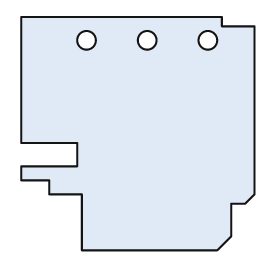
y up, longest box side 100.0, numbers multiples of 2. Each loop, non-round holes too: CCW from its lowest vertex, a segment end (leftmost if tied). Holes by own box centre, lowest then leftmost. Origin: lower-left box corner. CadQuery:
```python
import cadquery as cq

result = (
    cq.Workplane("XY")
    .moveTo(26.0, 0.0)
    .lineTo(84.0, 0.0)
    .lineTo(90.0, 6.0)
    .lineTo(90.0, 20.0)
    .lineTo(96.0, 20.0)
    .lineTo(100.0, 24.0)
    .lineTo(100.0, 96.0)
    .lineTo(86.0, 96.0)
    .lineTo(86.0, 100.0)
    .lineTo(0.0, 100.0)
    .lineTo(0.0, 46.0)
    .lineTo(24.0, 46.0)
    .lineTo(24.0, 36.0)
    .lineTo(0.0, 36.0)
    .lineTo(0.0, 30.0)
    .lineTo(12.0, 30.0)
    .lineTo(12.0, 24.0)
    .lineTo(26.0, 24.0)
    .close()
    .moveTo(28.0, 90.0)
    .circle(4.0)
    .moveTo(54.0, 90.0)
    .circle(4.0)
    .moveTo(80.0, 90.0)
    .circle(4.0)
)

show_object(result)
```